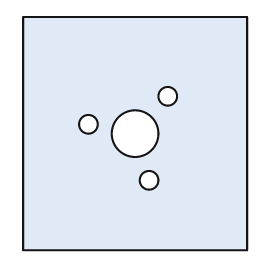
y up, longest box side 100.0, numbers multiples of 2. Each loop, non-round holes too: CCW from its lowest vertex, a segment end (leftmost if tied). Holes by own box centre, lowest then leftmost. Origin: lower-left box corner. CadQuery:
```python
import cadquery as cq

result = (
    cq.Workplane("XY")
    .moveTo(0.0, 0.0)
    .lineTo(96.0, 0.0)
    .lineTo(96.0, 100.0)
    .lineTo(0.0, 100.0)
    .close()
    .moveTo(54.0, 30.0)
    .circle(4.0)
    .moveTo(48.0, 50.0)
    .circle(10.0)
    .moveTo(28.0, 54.0)
    .circle(4.0)
    .moveTo(62.0, 66.0)
    .circle(4.0)
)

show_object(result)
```